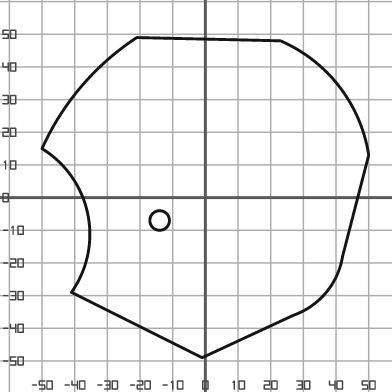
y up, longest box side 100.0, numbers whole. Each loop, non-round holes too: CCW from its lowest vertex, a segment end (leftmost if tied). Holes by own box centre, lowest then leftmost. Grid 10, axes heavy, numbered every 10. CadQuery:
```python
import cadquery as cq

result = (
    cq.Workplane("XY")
    .moveTo(-1.0, -49.0)
    .lineTo(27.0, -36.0)
    .threePointArc((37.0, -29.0), (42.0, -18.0))
    .lineTo(50.0, 13.0)
    .threePointArc((41.0, 34.0), (23.0, 48.0))
    .lineTo(-21.0, 49.0)
    .threePointArc((-38.0, 34.0), (-50.0, 15.0))
    .threePointArc((-36.0, -5.0), (-41.0, -29.0))
    .close()
    .moveTo(-14.0, -7.0)
    .circle(3.0)
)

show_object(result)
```